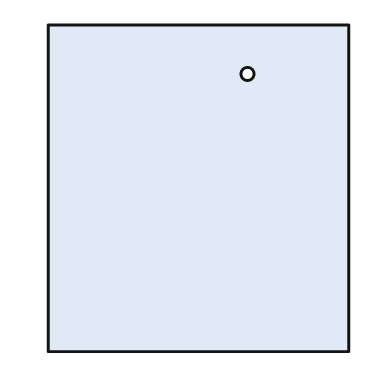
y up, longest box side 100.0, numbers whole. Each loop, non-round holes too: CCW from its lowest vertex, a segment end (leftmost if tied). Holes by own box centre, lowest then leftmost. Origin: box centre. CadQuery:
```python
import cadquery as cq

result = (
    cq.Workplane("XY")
    .moveTo(-46.0, -50.0)
    .lineTo(46.0, -50.0)
    .lineTo(46.0, 50.0)
    .lineTo(-46.0, 50.0)
    .close()
    .moveTo(15.0, 35.0)
    .circle(2.0)
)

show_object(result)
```